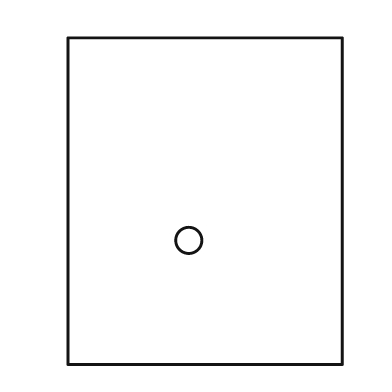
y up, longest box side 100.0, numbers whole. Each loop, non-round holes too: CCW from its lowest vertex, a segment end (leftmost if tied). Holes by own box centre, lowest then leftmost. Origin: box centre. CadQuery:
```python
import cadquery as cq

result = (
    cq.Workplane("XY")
    .moveTo(-42.0, -50.0)
    .lineTo(42.0, -50.0)
    .lineTo(42.0, 50.0)
    .lineTo(-42.0, 50.0)
    .close()
    .moveTo(-5.0, -12.0)
    .circle(4.0)
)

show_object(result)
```